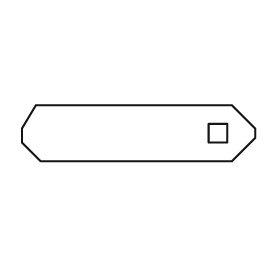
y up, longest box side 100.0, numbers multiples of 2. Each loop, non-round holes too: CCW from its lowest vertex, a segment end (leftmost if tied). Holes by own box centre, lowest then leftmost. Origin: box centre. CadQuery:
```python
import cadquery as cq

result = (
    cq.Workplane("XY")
    .moveTo(-42.0, -12.0)
    .lineTo(40.0, -12.0)
    .lineTo(50.0, -2.0)
    .lineTo(50.0, 2.0)
    .lineTo(40.0, 12.0)
    .lineTo(-44.0, 12.0)
    .lineTo(-50.0, 2.0)
    .lineTo(-50.0, -4.0)
    .close()
    .moveTo(30.0, -4.0)
    .lineTo(38.0, -4.0)
    .lineTo(38.0, 4.0)
    .lineTo(30.0, 4.0)
    .close()
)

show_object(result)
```